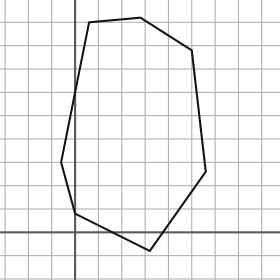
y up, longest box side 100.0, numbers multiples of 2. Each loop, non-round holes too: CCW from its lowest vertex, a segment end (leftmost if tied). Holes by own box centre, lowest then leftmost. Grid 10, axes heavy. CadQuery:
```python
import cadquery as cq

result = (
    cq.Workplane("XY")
    .moveTo(32.0, -8.0)
    .lineTo(56.0, 26.0)
    .lineTo(50.0, 78.0)
    .lineTo(28.0, 92.0)
    .lineTo(6.0, 90.0)
    .lineTo(-6.0, 30.0)
    .lineTo(0.0, 8.0)
    .close()
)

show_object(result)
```